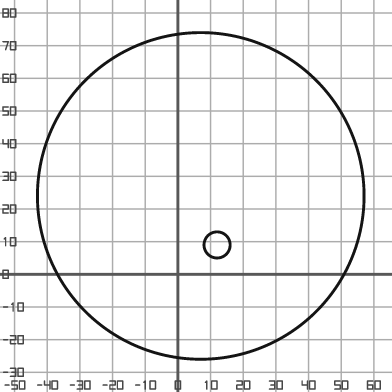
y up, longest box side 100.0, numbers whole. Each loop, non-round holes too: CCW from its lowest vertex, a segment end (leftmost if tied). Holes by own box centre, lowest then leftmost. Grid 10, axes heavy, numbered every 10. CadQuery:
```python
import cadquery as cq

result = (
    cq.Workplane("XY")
    .moveTo(7.0, 24.0)
    .circle(50.0)
    .moveTo(12.0, 9.0)
    .circle(4.0)
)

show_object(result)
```